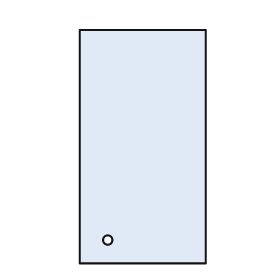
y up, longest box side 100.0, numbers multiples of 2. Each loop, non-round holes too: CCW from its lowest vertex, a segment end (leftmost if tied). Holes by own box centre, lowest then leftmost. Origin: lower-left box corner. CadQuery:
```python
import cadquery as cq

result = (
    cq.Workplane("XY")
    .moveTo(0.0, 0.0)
    .lineTo(54.0, 0.0)
    .lineTo(54.0, 100.0)
    .lineTo(0.0, 100.0)
    .close()
    .moveTo(12.0, 10.0)
    .circle(2.0)
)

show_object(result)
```